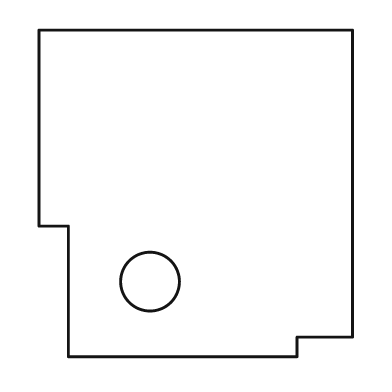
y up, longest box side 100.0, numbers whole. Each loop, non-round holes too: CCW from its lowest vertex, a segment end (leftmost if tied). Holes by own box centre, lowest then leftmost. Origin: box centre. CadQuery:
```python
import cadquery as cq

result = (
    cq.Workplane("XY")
    .moveTo(-39.0, -50.0)
    .lineTo(31.0, -50.0)
    .lineTo(31.0, -44.0)
    .lineTo(48.0, -44.0)
    .lineTo(48.0, 50.0)
    .lineTo(-48.0, 50.0)
    .lineTo(-48.0, -10.0)
    .lineTo(-39.0, -10.0)
    .close()
    .moveTo(-14.0, -27.0)
    .circle(9.0)
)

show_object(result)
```